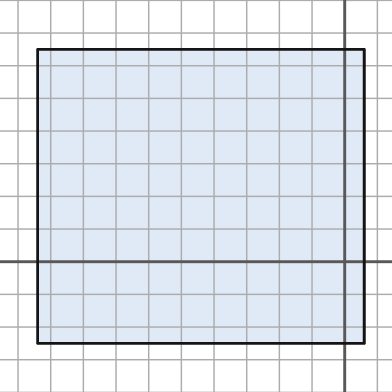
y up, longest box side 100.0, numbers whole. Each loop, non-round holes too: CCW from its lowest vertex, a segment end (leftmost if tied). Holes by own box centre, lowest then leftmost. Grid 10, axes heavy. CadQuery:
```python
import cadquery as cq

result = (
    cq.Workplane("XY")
    .moveTo(-94.0, -25.0)
    .lineTo(6.0, -25.0)
    .lineTo(6.0, 65.0)
    .lineTo(-94.0, 65.0)
    .close()
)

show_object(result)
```